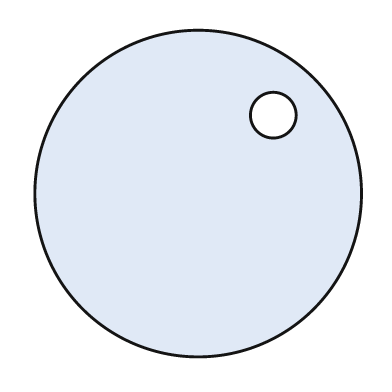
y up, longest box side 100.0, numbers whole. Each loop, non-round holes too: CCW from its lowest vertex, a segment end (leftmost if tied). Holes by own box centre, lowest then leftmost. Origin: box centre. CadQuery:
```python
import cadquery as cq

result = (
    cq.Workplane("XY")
    .moveTo(0.0, 0.0)
    .circle(50.0)
    .moveTo(23.0, 24.0)
    .circle(7.0)
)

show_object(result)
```